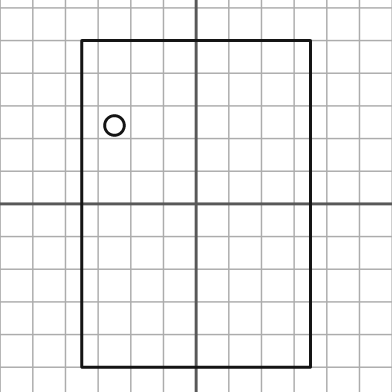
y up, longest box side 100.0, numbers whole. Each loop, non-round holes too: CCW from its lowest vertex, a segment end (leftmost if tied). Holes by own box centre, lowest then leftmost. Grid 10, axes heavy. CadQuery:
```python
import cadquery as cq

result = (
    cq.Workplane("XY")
    .moveTo(-35.0, -50.0)
    .lineTo(35.0, -50.0)
    .lineTo(35.0, 50.0)
    .lineTo(-35.0, 50.0)
    .close()
    .moveTo(-25.0, 24.0)
    .circle(3.0)
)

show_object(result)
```